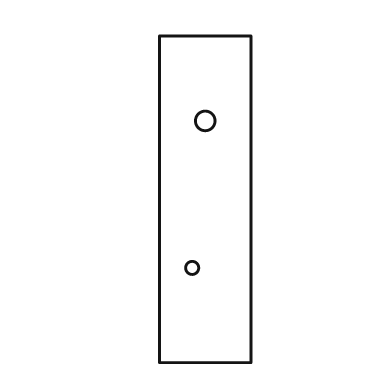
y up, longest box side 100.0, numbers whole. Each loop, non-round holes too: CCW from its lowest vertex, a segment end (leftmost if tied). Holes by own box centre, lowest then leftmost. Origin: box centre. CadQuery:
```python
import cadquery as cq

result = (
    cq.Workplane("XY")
    .moveTo(-14.0, -50.0)
    .lineTo(14.0, -50.0)
    .lineTo(14.0, 50.0)
    .lineTo(-14.0, 50.0)
    .close()
    .moveTo(-4.0, -21.0)
    .circle(2.0)
    .moveTo(0.0, 24.0)
    .circle(3.0)
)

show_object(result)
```